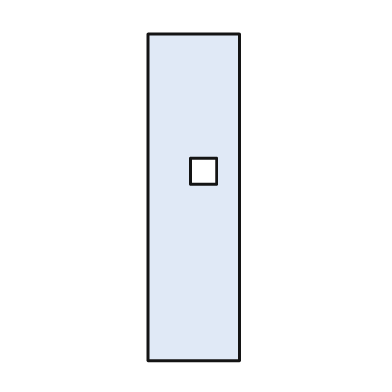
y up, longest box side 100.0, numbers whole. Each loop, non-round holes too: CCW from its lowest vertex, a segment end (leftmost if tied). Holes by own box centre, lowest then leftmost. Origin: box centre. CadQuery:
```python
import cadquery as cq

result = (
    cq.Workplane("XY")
    .moveTo(-14.0, -50.0)
    .lineTo(14.0, -50.0)
    .lineTo(14.0, 50.0)
    .lineTo(-14.0, 50.0)
    .close()
    .moveTo(-1.0, 4.0)
    .lineTo(7.0, 4.0)
    .lineTo(7.0, 12.0)
    .lineTo(-1.0, 12.0)
    .close()
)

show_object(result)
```